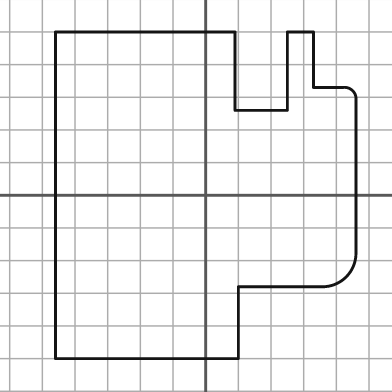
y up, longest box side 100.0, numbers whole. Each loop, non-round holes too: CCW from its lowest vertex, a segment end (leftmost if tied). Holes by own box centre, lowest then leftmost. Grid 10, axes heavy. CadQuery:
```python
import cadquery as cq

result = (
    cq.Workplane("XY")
    .moveTo(-46.0, -50.0)
    .lineTo(10.0, -50.0)
    .lineTo(10.0, -28.0)
    .lineTo(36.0, -28.0)
    .threePointArc((43.0, -25.0), (46.0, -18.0))
    .lineTo(46.0, 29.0)
    .threePointArc((45.0, 32.0), (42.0, 33.0))
    .lineTo(33.0, 33.0)
    .lineTo(33.0, 50.0)
    .lineTo(25.0, 50.0)
    .lineTo(25.0, 26.0)
    .lineTo(9.0, 26.0)
    .lineTo(9.0, 50.0)
    .lineTo(-46.0, 50.0)
    .close()
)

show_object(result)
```